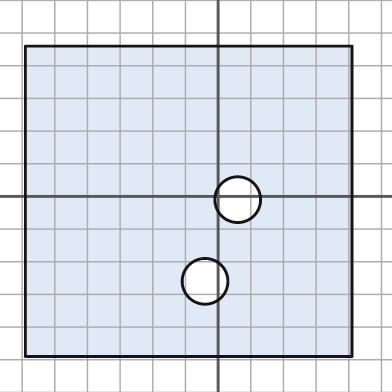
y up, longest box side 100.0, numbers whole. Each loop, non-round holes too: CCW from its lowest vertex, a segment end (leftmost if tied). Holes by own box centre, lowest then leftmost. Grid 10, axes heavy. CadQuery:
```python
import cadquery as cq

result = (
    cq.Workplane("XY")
    .moveTo(-59.0, -49.0)
    .lineTo(41.0, -49.0)
    .lineTo(41.0, 46.0)
    .lineTo(-59.0, 46.0)
    .close()
    .moveTo(-4.0, -26.0)
    .circle(7.0)
    .moveTo(6.0, -1.0)
    .circle(7.0)
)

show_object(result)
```